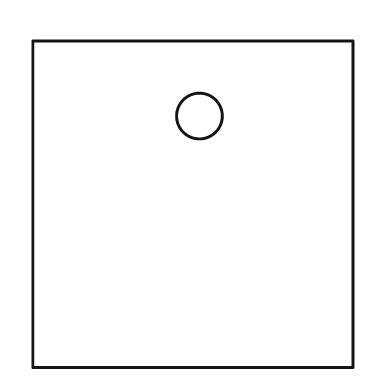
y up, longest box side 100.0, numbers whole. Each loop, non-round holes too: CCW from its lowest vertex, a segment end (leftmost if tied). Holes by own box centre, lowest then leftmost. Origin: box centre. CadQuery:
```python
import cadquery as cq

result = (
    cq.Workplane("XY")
    .moveTo(-49.0, -50.0)
    .lineTo(49.0, -50.0)
    .lineTo(49.0, 50.0)
    .lineTo(-49.0, 50.0)
    .close()
    .moveTo(2.0, 27.0)
    .circle(7.0)
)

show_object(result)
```